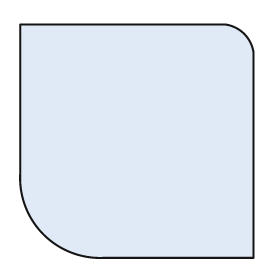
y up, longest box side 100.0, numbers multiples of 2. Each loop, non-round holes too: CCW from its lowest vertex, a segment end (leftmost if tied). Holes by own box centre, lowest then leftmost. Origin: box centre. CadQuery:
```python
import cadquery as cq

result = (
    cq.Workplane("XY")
    .moveTo(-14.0, -50.0)
    .lineTo(50.0, -50.0)
    .lineTo(50.0, 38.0)
    .threePointArc((46.0, 46.0), (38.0, 50.0))
    .lineTo(-50.0, 50.0)
    .lineTo(-50.0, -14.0)
    .threePointArc((-40.0, -40.0), (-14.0, -50.0))
    .close()
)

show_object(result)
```